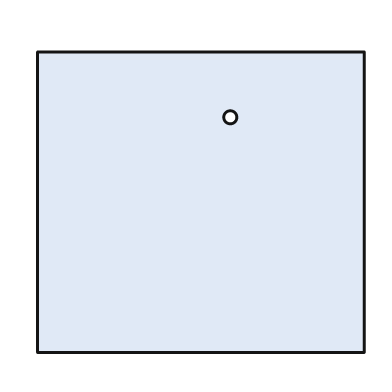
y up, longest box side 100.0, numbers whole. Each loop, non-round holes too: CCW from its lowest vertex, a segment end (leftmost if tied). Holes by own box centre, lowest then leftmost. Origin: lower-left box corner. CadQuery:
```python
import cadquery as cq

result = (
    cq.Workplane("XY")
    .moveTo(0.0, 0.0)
    .lineTo(100.0, 0.0)
    .lineTo(100.0, 92.0)
    .lineTo(0.0, 92.0)
    .close()
    .moveTo(59.0, 72.0)
    .circle(2.0)
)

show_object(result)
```